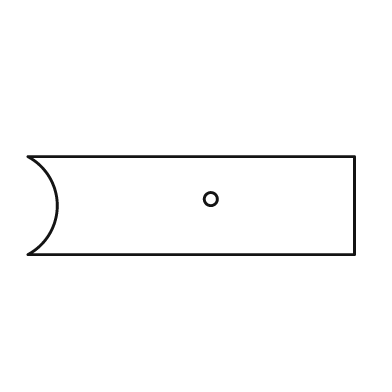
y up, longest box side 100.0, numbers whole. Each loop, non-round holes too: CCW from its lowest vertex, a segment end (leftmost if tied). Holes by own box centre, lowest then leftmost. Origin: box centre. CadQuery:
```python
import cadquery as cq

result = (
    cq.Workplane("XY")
    .moveTo(-50.0, -15.0)
    .lineTo(50.0, -15.0)
    .lineTo(50.0, 15.0)
    .lineTo(-50.0, 15.0)
    .threePointArc((-41.0, 0.0), (-50.0, -15.0))
    .close()
    .moveTo(6.0, 2.0)
    .circle(2.0)
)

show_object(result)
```